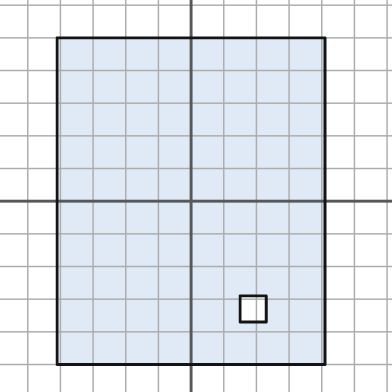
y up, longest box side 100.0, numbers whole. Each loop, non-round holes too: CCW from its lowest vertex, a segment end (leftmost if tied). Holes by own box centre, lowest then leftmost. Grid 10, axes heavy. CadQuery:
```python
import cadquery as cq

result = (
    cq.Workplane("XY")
    .moveTo(-41.0, -50.0)
    .lineTo(41.0, -50.0)
    .lineTo(41.0, 50.0)
    .lineTo(-41.0, 50.0)
    .close()
    .moveTo(15.0, -37.0)
    .lineTo(23.0, -37.0)
    .lineTo(23.0, -29.0)
    .lineTo(15.0, -29.0)
    .close()
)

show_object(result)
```